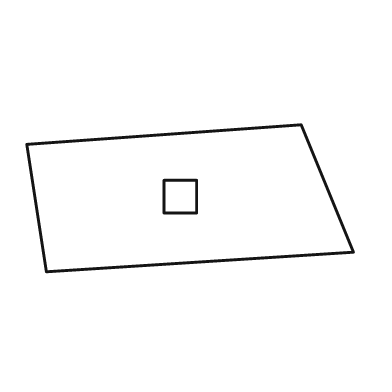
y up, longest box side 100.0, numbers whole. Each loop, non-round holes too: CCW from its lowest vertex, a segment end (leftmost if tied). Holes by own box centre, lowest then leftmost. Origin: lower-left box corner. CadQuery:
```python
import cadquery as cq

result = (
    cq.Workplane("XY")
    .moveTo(6.0, 0.0)
    .lineTo(100.0, 6.0)
    .lineTo(84.0, 45.0)
    .lineTo(0.0, 39.0)
    .close()
    .moveTo(42.0, 18.0)
    .lineTo(52.0, 18.0)
    .lineTo(52.0, 28.0)
    .lineTo(42.0, 28.0)
    .close()
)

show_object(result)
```